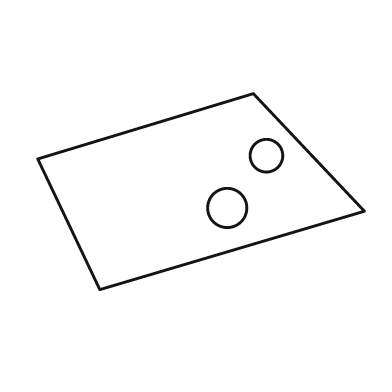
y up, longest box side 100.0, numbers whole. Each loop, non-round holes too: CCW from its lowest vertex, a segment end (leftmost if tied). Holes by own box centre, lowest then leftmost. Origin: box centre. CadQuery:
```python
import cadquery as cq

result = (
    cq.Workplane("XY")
    .moveTo(-31.0, -30.0)
    .lineTo(50.0, -6.0)
    .lineTo(16.0, 30.0)
    .lineTo(-50.0, 10.0)
    .close()
    .moveTo(8.0, -5.0)
    .circle(6.0)
    .moveTo(20.0, 11.0)
    .circle(5.0)
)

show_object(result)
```